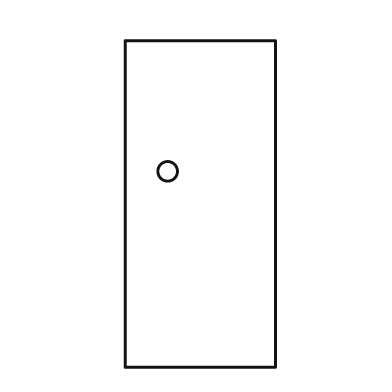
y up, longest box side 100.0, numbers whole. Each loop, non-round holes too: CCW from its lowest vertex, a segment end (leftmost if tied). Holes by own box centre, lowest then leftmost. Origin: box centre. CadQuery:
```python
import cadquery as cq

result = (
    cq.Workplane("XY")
    .moveTo(-23.0, -50.0)
    .lineTo(23.0, -50.0)
    .lineTo(23.0, 50.0)
    .lineTo(-23.0, 50.0)
    .close()
    .moveTo(-10.0, 10.0)
    .circle(3.0)
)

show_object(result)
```